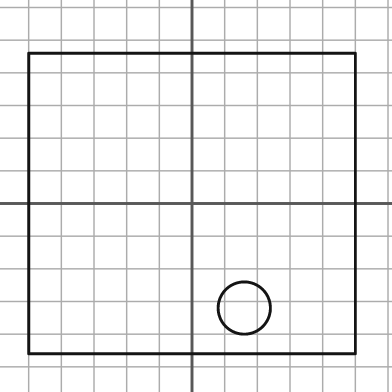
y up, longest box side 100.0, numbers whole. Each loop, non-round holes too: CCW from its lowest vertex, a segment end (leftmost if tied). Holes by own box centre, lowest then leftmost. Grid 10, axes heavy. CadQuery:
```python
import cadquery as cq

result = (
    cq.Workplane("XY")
    .moveTo(-50.0, -46.0)
    .lineTo(50.0, -46.0)
    .lineTo(50.0, 46.0)
    .lineTo(-50.0, 46.0)
    .close()
    .moveTo(16.0, -32.0)
    .circle(8.0)
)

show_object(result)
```